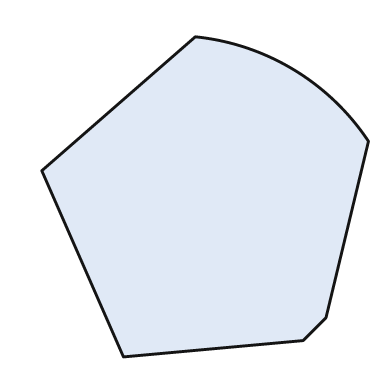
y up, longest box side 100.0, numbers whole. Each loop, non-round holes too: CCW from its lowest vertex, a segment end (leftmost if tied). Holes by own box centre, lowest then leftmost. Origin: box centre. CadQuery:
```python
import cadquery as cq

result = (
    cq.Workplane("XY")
    .moveTo(-25.0, -49.0)
    .lineTo(30.0, -44.0)
    .lineTo(37.0, -37.0)
    .lineTo(50.0, 17.0)
    .threePointArc((27.0, 39.0), (-3.0, 49.0))
    .lineTo(-50.0, 8.0)
    .close()
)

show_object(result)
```